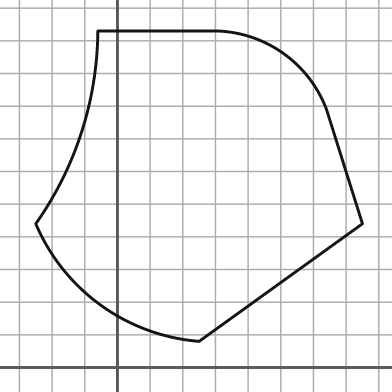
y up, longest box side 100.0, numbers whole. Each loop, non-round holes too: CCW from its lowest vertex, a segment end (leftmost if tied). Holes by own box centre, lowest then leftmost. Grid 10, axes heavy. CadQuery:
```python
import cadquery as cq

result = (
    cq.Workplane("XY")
    .moveTo(25.0, 8.0)
    .lineTo(75.0, 44.0)
    .lineTo(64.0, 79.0)
    .threePointArc((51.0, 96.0), (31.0, 103.0))
    .lineTo(-6.0, 103.0)
    .threePointArc((-11.0, 72.0), (-25.0, 44.0))
    .threePointArc((-5.0, 19.0), (25.0, 8.0))
    .close()
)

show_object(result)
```